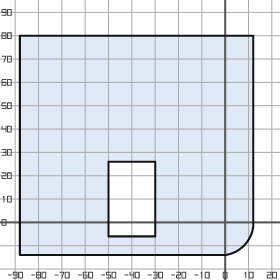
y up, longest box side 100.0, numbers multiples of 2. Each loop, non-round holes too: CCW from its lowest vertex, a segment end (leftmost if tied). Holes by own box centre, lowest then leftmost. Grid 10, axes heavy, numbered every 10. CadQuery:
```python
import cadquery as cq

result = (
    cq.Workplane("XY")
    .moveTo(-88.0, -14.0)
    .lineTo(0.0, -14.0)
    .threePointArc((8.0, -10.0), (12.0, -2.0))
    .lineTo(12.0, 80.0)
    .lineTo(-88.0, 80.0)
    .close()
    .moveTo(-50.0, -6.0)
    .lineTo(-30.0, -6.0)
    .lineTo(-30.0, 26.0)
    .lineTo(-50.0, 26.0)
    .close()
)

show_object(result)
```